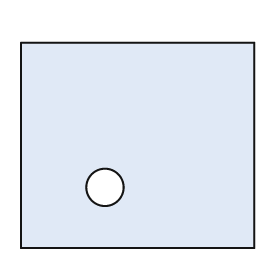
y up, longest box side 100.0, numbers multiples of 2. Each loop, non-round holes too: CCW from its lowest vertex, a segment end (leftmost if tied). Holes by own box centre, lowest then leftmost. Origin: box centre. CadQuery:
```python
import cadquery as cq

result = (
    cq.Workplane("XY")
    .moveTo(-50.0, -44.0)
    .lineTo(50.0, -44.0)
    .lineTo(50.0, 44.0)
    .lineTo(-50.0, 44.0)
    .close()
    .moveTo(-14.0, -18.0)
    .circle(8.0)
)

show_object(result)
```